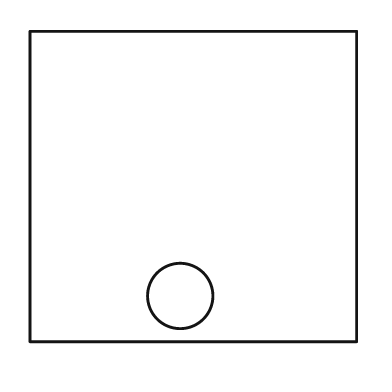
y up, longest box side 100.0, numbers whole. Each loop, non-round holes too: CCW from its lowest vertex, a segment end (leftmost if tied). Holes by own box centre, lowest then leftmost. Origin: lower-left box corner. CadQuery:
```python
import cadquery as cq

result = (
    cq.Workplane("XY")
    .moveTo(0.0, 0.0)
    .lineTo(100.0, 0.0)
    .lineTo(100.0, 95.0)
    .lineTo(0.0, 95.0)
    .close()
    .moveTo(46.0, 14.0)
    .circle(10.0)
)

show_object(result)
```